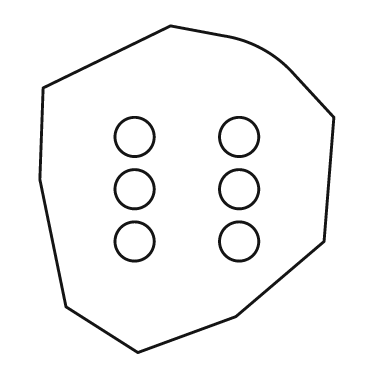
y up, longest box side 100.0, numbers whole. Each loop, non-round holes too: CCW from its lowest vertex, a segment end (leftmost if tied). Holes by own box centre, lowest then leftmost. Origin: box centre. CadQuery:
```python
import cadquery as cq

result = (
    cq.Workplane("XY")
    .moveTo(-15.0, -50.0)
    .lineTo(15.0, -39.0)
    .lineTo(42.0, -16.0)
    .lineTo(45.0, 22.0)
    .lineTo(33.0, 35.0)
    .threePointArc((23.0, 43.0), (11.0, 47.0))
    .lineTo(-5.0, 50.0)
    .lineTo(-44.0, 31.0)
    .lineTo(-45.0, 3.0)
    .lineTo(-37.0, -36.0)
    .close()
    .moveTo(-16.0, -16.0)
    .circle(6.0)
    .moveTo(16.0, -16.0)
    .circle(6.0)
    .moveTo(-16.0, 0.0)
    .circle(6.0)
    .moveTo(16.0, 0.0)
    .circle(6.0)
    .moveTo(-16.0, 16.0)
    .circle(6.0)
    .moveTo(16.0, 16.0)
    .circle(6.0)
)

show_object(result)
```